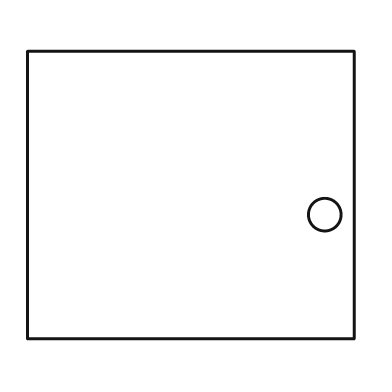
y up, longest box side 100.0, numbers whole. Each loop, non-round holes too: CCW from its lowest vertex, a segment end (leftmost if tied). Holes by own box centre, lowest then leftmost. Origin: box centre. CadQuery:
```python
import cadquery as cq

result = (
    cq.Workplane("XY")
    .moveTo(-50.0, -44.0)
    .lineTo(50.0, -44.0)
    .lineTo(50.0, 44.0)
    .lineTo(-50.0, 44.0)
    .close()
    .moveTo(41.0, -6.0)
    .circle(5.0)
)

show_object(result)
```